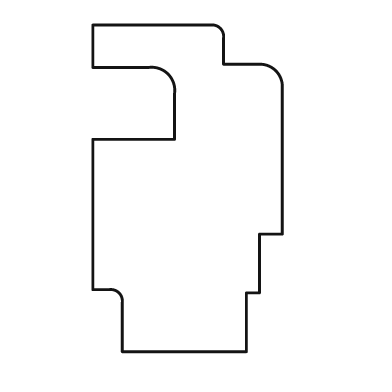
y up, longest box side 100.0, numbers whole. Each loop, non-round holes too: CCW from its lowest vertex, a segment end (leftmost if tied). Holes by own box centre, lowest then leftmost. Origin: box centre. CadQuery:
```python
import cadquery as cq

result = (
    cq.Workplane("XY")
    .moveTo(-20.0, -50.0)
    .lineTo(18.0, -50.0)
    .lineTo(18.0, -32.0)
    .lineTo(22.0, -32.0)
    .lineTo(22.0, -14.0)
    .lineTo(29.0, -14.0)
    .lineTo(29.0, 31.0)
    .threePointArc((27.0, 36.0), (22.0, 38.0))
    .lineTo(11.0, 38.0)
    .lineTo(11.0, 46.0)
    .threePointArc((10.0, 49.0), (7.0, 50.0))
    .lineTo(-29.0, 50.0)
    .lineTo(-29.0, 37.0)
    .lineTo(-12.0, 37.0)
    .threePointArc((-6.0, 35.0), (-4.0, 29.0))
    .lineTo(-4.0, 15.0)
    .lineTo(-29.0, 15.0)
    .lineTo(-29.0, -31.0)
    .lineTo(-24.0, -31.0)
    .threePointArc((-21.0, -32.0), (-20.0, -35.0))
    .close()
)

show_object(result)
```